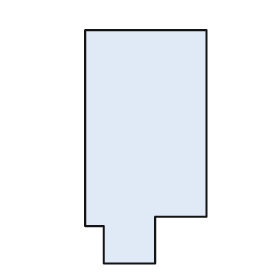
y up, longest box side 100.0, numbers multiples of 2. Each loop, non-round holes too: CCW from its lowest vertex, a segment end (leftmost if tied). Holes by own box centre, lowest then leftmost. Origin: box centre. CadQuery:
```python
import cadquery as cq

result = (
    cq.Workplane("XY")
    .moveTo(-18.0, -50.0)
    .lineTo(4.0, -50.0)
    .lineTo(4.0, -30.0)
    .lineTo(26.0, -30.0)
    .lineTo(26.0, 50.0)
    .lineTo(-26.0, 50.0)
    .lineTo(-26.0, -34.0)
    .lineTo(-18.0, -34.0)
    .close()
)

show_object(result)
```